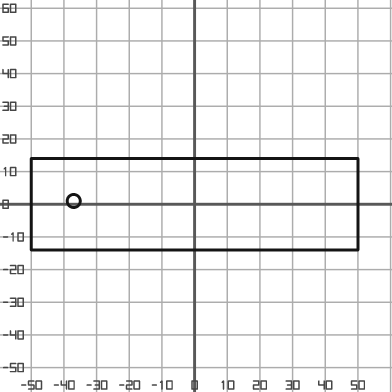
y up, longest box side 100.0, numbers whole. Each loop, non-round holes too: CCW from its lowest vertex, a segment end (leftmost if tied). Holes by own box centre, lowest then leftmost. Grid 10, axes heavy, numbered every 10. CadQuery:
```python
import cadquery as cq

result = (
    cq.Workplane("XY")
    .moveTo(-50.0, -14.0)
    .lineTo(50.0, -14.0)
    .lineTo(50.0, 14.0)
    .lineTo(-50.0, 14.0)
    .close()
    .moveTo(-37.0, 1.0)
    .circle(2.0)
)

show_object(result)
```